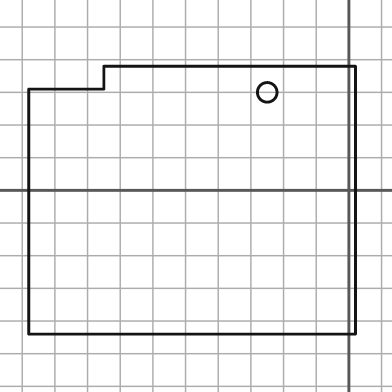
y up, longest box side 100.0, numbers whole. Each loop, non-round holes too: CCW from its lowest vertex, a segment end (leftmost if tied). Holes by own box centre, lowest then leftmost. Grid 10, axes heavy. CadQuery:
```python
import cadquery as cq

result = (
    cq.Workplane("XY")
    .moveTo(-98.0, -44.0)
    .lineTo(2.0, -44.0)
    .lineTo(2.0, 38.0)
    .lineTo(-75.0, 38.0)
    .lineTo(-75.0, 31.0)
    .lineTo(-98.0, 31.0)
    .close()
    .moveTo(-25.0, 30.0)
    .circle(3.0)
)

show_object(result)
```